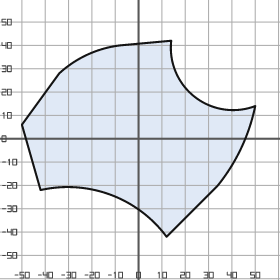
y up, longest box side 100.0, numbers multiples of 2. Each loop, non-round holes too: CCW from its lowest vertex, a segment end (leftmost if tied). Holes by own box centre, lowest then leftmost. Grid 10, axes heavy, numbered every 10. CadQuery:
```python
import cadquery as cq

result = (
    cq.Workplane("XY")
    .moveTo(12.0, -42.0)
    .lineTo(34.0, -20.0)
    .threePointArc((44.0, -4.0), (50.0, 14.0))
    .threePointArc((24.0, 18.0), (14.0, 42.0))
    .lineTo(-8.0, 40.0)
    .threePointArc((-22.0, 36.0), (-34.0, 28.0))
    .lineTo(-50.0, 6.0)
    .lineTo(-42.0, -22.0)
    .threePointArc((-12.0, -24.0), (12.0, -42.0))
    .close()
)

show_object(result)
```